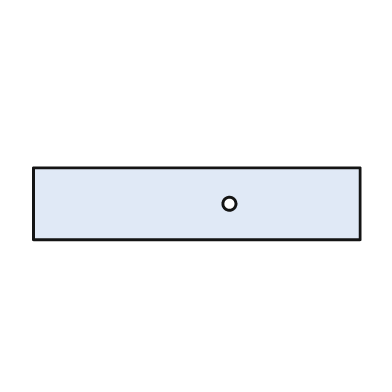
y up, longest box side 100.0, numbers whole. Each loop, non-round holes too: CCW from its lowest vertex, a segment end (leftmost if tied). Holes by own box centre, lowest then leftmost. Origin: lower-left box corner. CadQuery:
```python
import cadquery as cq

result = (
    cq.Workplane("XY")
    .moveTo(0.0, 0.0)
    .lineTo(100.0, 0.0)
    .lineTo(100.0, 22.0)
    .lineTo(0.0, 22.0)
    .close()
    .moveTo(60.0, 11.0)
    .circle(2.0)
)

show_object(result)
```